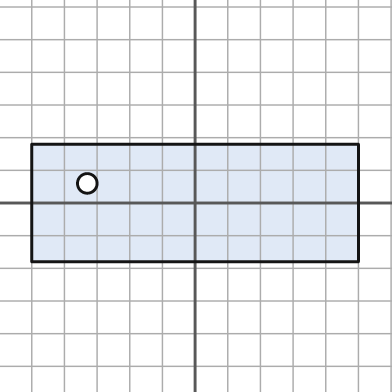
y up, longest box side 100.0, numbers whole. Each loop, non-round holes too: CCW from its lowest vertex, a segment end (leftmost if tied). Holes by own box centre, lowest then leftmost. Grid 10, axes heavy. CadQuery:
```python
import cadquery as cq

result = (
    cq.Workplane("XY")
    .moveTo(-50.0, -18.0)
    .lineTo(50.0, -18.0)
    .lineTo(50.0, 18.0)
    .lineTo(-50.0, 18.0)
    .close()
    .moveTo(-33.0, 6.0)
    .circle(3.0)
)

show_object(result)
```